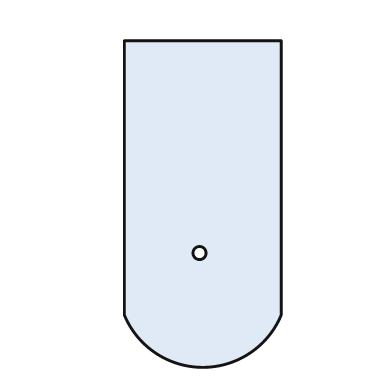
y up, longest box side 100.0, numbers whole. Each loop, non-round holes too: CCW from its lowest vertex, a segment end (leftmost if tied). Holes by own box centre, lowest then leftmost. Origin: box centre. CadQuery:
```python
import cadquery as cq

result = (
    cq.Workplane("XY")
    .moveTo(-24.0, -34.0)
    .threePointArc((0.0, -50.0), (24.0, -34.0))
    .lineTo(24.0, 50.0)
    .lineTo(-24.0, 50.0)
    .close()
    .moveTo(-1.0, -15.0)
    .circle(2.0)
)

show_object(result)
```